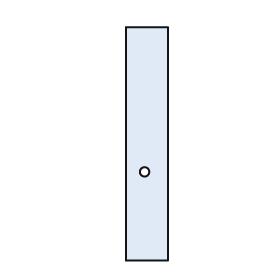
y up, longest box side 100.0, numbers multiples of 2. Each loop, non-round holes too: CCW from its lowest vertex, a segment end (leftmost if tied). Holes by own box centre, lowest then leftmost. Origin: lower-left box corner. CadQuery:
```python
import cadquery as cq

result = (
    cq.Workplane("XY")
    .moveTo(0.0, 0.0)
    .lineTo(18.0, 0.0)
    .lineTo(18.0, 100.0)
    .lineTo(0.0, 100.0)
    .close()
    .moveTo(8.0, 38.0)
    .circle(2.0)
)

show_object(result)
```